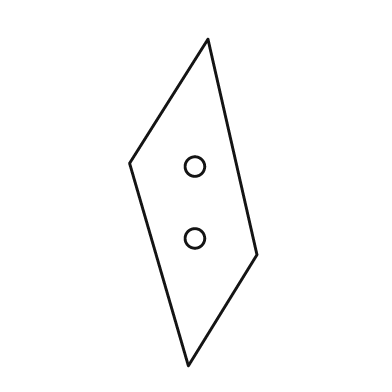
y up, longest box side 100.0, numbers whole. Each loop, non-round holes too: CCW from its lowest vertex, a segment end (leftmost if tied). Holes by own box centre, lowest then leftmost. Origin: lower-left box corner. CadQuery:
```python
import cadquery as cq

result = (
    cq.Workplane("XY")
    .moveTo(18.0, 0.0)
    .lineTo(39.0, 34.0)
    .lineTo(24.0, 100.0)
    .lineTo(0.0, 62.0)
    .close()
    .moveTo(20.0, 39.0)
    .circle(3.0)
    .moveTo(20.0, 61.0)
    .circle(3.0)
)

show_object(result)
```